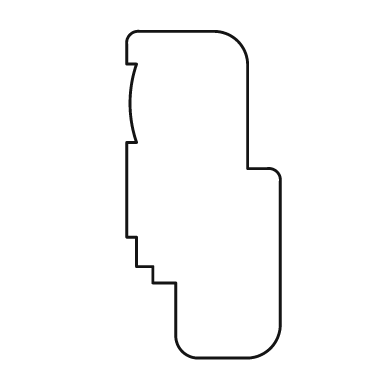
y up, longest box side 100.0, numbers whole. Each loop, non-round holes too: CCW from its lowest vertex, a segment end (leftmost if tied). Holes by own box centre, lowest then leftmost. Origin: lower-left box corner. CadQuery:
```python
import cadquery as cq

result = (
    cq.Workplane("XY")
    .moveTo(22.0, 0.0)
    .lineTo(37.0, 0.0)
    .threePointArc((44.0, 3.0), (47.0, 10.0))
    .lineTo(47.0, 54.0)
    .threePointArc((46.0, 57.0), (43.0, 58.0))
    .lineTo(37.0, 58.0)
    .lineTo(37.0, 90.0)
    .threePointArc((34.0, 97.0), (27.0, 100.0))
    .lineTo(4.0, 100.0)
    .threePointArc((1.0, 99.0), (0.0, 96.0))
    .lineTo(0.0, 90.0)
    .lineTo(3.0, 90.0)
    .threePointArc((1.0, 78.0), (3.0, 66.0))
    .lineTo(0.0, 66.0)
    .lineTo(0.0, 37.0)
    .lineTo(3.0, 37.0)
    .lineTo(3.0, 28.0)
    .lineTo(8.0, 28.0)
    .lineTo(8.0, 23.0)
    .lineTo(15.0, 23.0)
    .lineTo(15.0, 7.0)
    .threePointArc((17.0, 2.0), (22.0, 0.0))
    .close()
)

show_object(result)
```